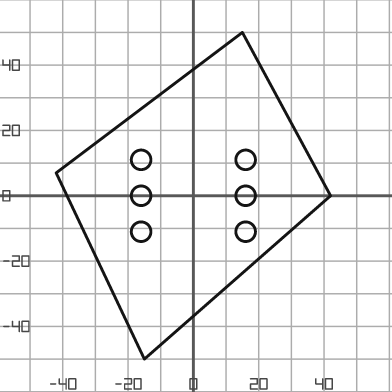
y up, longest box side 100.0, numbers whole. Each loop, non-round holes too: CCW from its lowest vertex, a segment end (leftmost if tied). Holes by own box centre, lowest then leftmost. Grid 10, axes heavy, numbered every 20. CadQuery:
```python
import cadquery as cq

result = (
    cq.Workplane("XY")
    .moveTo(-15.0, -50.0)
    .lineTo(42.0, 0.0)
    .lineTo(15.0, 50.0)
    .lineTo(-42.0, 7.0)
    .close()
    .moveTo(-16.0, -11.0)
    .circle(3.0)
    .moveTo(16.0, -11.0)
    .circle(3.0)
    .moveTo(-16.0, 0.0)
    .circle(3.0)
    .moveTo(16.0, 0.0)
    .circle(3.0)
    .moveTo(-16.0, 11.0)
    .circle(3.0)
    .moveTo(16.0, 11.0)
    .circle(3.0)
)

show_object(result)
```